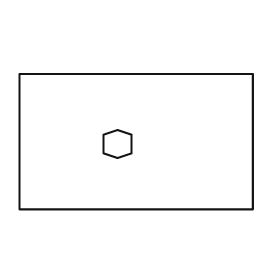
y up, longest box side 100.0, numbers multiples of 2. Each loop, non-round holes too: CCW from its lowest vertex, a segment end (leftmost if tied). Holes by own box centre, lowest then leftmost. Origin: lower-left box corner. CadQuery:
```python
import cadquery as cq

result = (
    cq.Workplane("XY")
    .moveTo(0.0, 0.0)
    .lineTo(100.0, 0.0)
    .lineTo(100.0, 58.0)
    .lineTo(0.0, 58.0)
    .close()
    .moveTo(42.0, 22.0)
    .lineTo(48.0, 24.0)
    .lineTo(48.0, 32.0)
    .lineTo(42.0, 34.0)
    .lineTo(36.0, 32.0)
    .lineTo(36.0, 24.0)
    .close()
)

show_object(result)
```